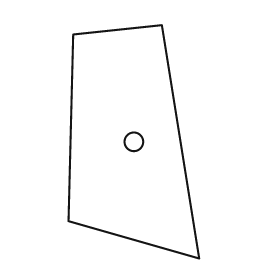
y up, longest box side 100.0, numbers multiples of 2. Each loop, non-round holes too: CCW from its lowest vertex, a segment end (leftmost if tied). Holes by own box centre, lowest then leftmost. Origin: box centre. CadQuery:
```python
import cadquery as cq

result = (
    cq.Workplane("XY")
    .moveTo(28.0, -50.0)
    .lineTo(12.0, 50.0)
    .lineTo(-26.0, 46.0)
    .lineTo(-28.0, -34.0)
    .close()
    .moveTo(0.0, 0.0)
    .circle(4.0)
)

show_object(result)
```